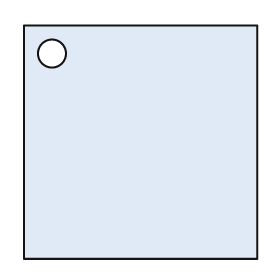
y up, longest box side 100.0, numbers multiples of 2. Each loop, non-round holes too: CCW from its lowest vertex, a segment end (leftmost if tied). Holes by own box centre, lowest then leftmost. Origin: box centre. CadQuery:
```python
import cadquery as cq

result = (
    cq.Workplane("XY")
    .moveTo(-50.0, -50.0)
    .lineTo(50.0, -50.0)
    .lineTo(50.0, 50.0)
    .lineTo(-50.0, 50.0)
    .close()
    .moveTo(-38.0, 38.0)
    .circle(6.0)
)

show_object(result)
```